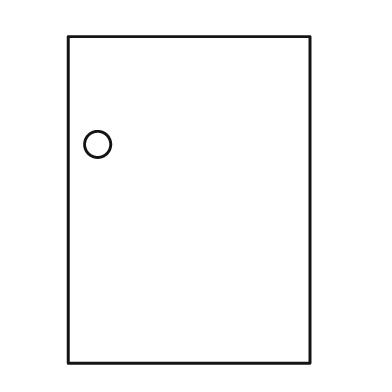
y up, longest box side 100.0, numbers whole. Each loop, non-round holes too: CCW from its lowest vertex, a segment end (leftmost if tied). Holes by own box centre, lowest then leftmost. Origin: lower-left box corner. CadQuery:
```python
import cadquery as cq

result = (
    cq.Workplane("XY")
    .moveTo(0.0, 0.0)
    .lineTo(74.0, 0.0)
    .lineTo(74.0, 100.0)
    .lineTo(0.0, 100.0)
    .close()
    .moveTo(9.0, 67.0)
    .circle(4.0)
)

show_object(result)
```